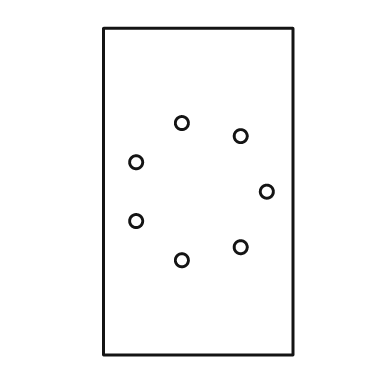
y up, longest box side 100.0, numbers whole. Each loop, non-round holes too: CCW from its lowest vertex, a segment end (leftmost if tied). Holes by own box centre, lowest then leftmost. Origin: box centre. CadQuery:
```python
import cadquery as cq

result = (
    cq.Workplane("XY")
    .moveTo(-29.0, -50.0)
    .lineTo(29.0, -50.0)
    .lineTo(29.0, 50.0)
    .lineTo(-29.0, 50.0)
    .close()
    .moveTo(-5.0, -21.0)
    .circle(2.0)
    .moveTo(13.0, -17.0)
    .circle(2.0)
    .moveTo(-19.0, -9.0)
    .circle(2.0)
    .moveTo(21.0, 0.0)
    .circle(2.0)
    .moveTo(-19.0, 9.0)
    .circle(2.0)
    .moveTo(13.0, 17.0)
    .circle(2.0)
    .moveTo(-5.0, 21.0)
    .circle(2.0)
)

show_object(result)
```